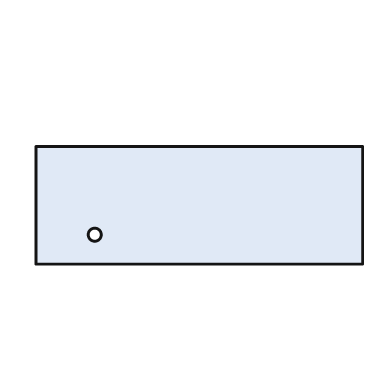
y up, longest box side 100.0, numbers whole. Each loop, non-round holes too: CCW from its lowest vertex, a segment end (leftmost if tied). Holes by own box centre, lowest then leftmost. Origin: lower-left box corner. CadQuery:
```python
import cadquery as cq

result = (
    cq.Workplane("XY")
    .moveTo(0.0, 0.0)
    .lineTo(100.0, 0.0)
    .lineTo(100.0, 36.0)
    .lineTo(0.0, 36.0)
    .close()
    .moveTo(18.0, 9.0)
    .circle(2.0)
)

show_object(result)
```